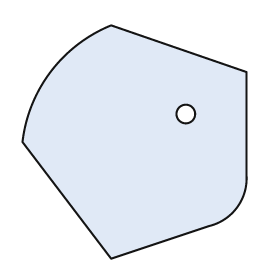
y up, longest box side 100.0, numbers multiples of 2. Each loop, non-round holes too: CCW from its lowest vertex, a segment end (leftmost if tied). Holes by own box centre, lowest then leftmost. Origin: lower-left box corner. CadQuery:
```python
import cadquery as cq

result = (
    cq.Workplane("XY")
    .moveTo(38.0, 0.0)
    .lineTo(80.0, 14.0)
    .threePointArc((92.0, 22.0), (96.0, 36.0))
    .lineTo(96.0, 80.0)
    .lineTo(38.0, 100.0)
    .threePointArc((12.0, 80.0), (0.0, 50.0))
    .close()
    .moveTo(70.0, 62.0)
    .circle(4.0)
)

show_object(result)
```